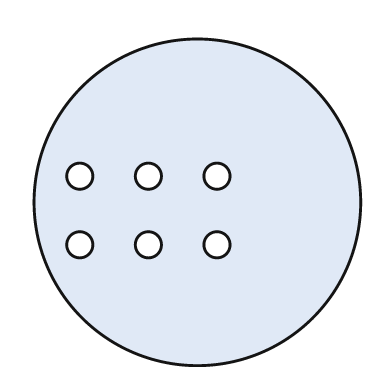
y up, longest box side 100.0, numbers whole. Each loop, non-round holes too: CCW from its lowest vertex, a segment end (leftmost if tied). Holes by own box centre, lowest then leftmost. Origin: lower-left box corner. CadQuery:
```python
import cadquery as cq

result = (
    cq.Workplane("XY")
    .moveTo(50.0, 50.0)
    .circle(50.0)
    .moveTo(14.0, 37.0)
    .circle(4.0)
    .moveTo(35.0, 37.0)
    .circle(4.0)
    .moveTo(56.0, 37.0)
    .circle(4.0)
    .moveTo(14.0, 58.0)
    .circle(4.0)
    .moveTo(35.0, 58.0)
    .circle(4.0)
    .moveTo(56.0, 58.0)
    .circle(4.0)
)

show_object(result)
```